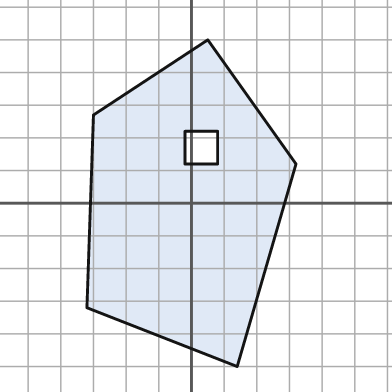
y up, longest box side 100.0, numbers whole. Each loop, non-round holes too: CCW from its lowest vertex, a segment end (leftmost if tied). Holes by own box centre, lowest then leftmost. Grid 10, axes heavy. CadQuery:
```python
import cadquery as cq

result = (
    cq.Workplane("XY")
    .moveTo(14.0, -50.0)
    .lineTo(32.0, 12.0)
    .lineTo(5.0, 50.0)
    .lineTo(-30.0, 27.0)
    .lineTo(-32.0, -32.0)
    .close()
    .moveTo(-2.0, 12.0)
    .lineTo(8.0, 12.0)
    .lineTo(8.0, 22.0)
    .lineTo(-2.0, 22.0)
    .close()
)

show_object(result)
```